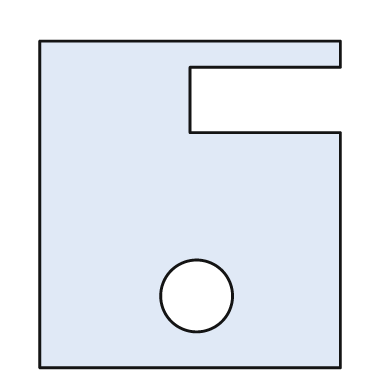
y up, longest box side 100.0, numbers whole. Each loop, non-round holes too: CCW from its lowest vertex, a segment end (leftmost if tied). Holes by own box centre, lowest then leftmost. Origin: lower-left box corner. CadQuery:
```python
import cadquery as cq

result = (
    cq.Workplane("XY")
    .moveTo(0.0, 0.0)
    .lineTo(92.0, 0.0)
    .lineTo(92.0, 72.0)
    .lineTo(46.0, 72.0)
    .lineTo(46.0, 92.0)
    .lineTo(92.0, 92.0)
    .lineTo(92.0, 100.0)
    .lineTo(0.0, 100.0)
    .close()
    .moveTo(48.0, 22.0)
    .circle(11.0)
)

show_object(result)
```